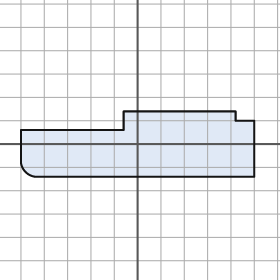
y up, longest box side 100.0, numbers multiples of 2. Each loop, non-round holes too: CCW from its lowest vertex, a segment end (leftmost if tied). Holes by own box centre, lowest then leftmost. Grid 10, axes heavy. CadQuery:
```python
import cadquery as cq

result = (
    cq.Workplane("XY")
    .moveTo(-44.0, -14.0)
    .lineTo(50.0, -14.0)
    .lineTo(50.0, 10.0)
    .lineTo(42.0, 10.0)
    .lineTo(42.0, 14.0)
    .lineTo(-6.0, 14.0)
    .lineTo(-6.0, 6.0)
    .lineTo(-50.0, 6.0)
    .lineTo(-50.0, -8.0)
    .threePointArc((-48.0, -12.0), (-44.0, -14.0))
    .close()
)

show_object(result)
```